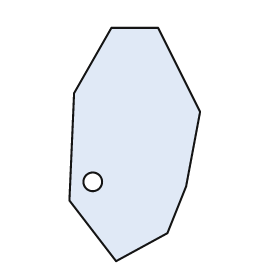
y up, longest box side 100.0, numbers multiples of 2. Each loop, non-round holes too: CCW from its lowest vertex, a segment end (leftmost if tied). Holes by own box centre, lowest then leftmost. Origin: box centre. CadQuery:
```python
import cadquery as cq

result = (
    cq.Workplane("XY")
    .moveTo(-8.0, -50.0)
    .lineTo(14.0, -38.0)
    .lineTo(22.0, -18.0)
    .lineTo(28.0, 14.0)
    .lineTo(10.0, 50.0)
    .lineTo(-10.0, 50.0)
    .lineTo(-26.0, 22.0)
    .lineTo(-28.0, -24.0)
    .close()
    .moveTo(-18.0, -16.0)
    .circle(4.0)
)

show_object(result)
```